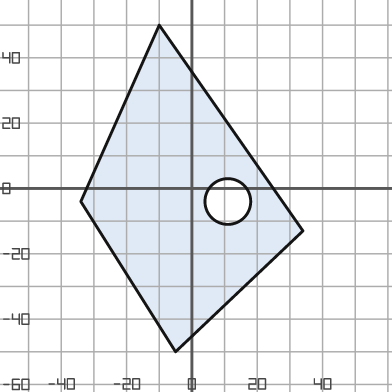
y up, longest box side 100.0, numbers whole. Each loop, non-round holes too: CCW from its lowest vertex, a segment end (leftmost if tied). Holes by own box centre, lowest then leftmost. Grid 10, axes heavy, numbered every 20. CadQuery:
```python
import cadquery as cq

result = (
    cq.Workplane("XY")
    .moveTo(-5.0, -50.0)
    .lineTo(34.0, -13.0)
    .lineTo(-10.0, 50.0)
    .lineTo(-34.0, -4.0)
    .close()
    .moveTo(11.0, -4.0)
    .circle(7.0)
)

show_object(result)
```